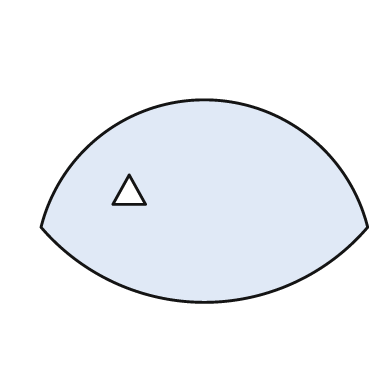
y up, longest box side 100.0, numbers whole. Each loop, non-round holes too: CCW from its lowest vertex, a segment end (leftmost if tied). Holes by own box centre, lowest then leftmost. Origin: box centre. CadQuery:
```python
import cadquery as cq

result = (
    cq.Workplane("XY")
    .moveTo(-50.0, -8.0)
    .threePointArc((0.0, -31.0), (50.0, -8.0))
    .threePointArc((0.0, 31.0), (-50.0, -8.0))
    .close()
    .moveTo(-28.0, -1.0)
    .lineTo(-18.0, -1.0)
    .lineTo(-23.0, 8.0)
    .close()
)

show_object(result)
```